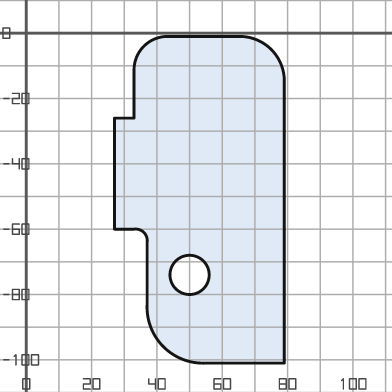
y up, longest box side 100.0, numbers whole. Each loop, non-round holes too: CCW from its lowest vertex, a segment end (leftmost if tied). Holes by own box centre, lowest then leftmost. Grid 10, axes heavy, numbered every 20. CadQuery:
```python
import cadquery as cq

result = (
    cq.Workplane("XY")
    .moveTo(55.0, -101.0)
    .lineTo(79.0, -101.0)
    .lineTo(79.0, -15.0)
    .threePointArc((75.0, -5.0), (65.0, -1.0))
    .lineTo(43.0, -1.0)
    .threePointArc((36.0, -4.0), (33.0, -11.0))
    .lineTo(33.0, -26.0)
    .lineTo(27.0, -26.0)
    .lineTo(27.0, -60.0)
    .lineTo(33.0, -60.0)
    .threePointArc((36.0, -61.0), (37.0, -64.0))
    .lineTo(37.0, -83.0)
    .threePointArc((42.0, -96.0), (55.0, -101.0))
    .close()
    .moveTo(50.0, -74.0)
    .circle(6.0)
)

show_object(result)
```